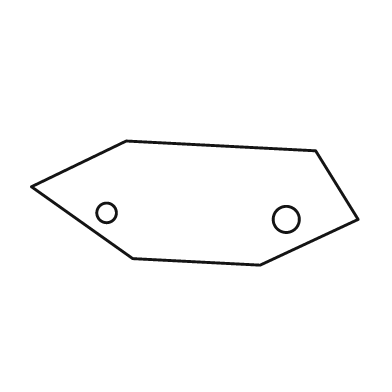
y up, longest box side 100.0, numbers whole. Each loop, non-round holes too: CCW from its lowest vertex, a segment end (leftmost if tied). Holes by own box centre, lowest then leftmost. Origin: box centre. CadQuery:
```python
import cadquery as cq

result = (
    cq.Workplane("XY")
    .moveTo(20.0, -19.0)
    .lineTo(50.0, -5.0)
    .lineTo(37.0, 16.0)
    .lineTo(-21.0, 19.0)
    .lineTo(-50.0, 5.0)
    .lineTo(-19.0, -17.0)
    .close()
    .moveTo(28.0, -5.0)
    .circle(4.0)
    .moveTo(-27.0, -3.0)
    .circle(3.0)
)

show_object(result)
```